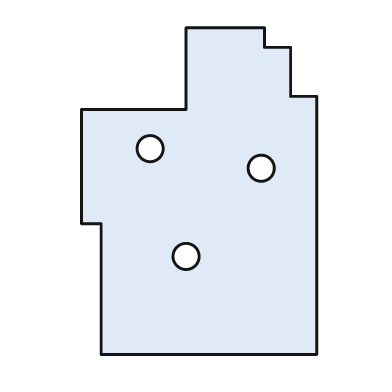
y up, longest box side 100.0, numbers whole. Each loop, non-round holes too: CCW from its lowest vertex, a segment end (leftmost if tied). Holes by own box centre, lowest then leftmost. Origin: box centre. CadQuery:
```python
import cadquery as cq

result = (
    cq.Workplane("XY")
    .moveTo(-30.0, -50.0)
    .lineTo(36.0, -50.0)
    .lineTo(36.0, 29.0)
    .lineTo(28.0, 29.0)
    .lineTo(28.0, 44.0)
    .lineTo(20.0, 44.0)
    .lineTo(20.0, 50.0)
    .lineTo(-4.0, 50.0)
    .lineTo(-4.0, 25.0)
    .lineTo(-36.0, 25.0)
    .lineTo(-36.0, -10.0)
    .lineTo(-30.0, -10.0)
    .close()
    .moveTo(-4.0, -20.0)
    .circle(4.0)
    .moveTo(19.0, 7.0)
    .circle(4.0)
    .moveTo(-15.0, 13.0)
    .circle(4.0)
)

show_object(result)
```